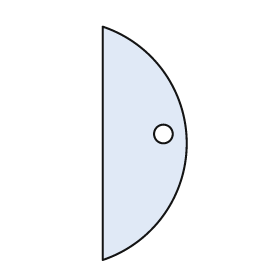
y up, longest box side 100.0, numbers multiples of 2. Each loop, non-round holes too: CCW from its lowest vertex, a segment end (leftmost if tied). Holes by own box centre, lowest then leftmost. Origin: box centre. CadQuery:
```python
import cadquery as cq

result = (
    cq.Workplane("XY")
    .moveTo(-18.0, -50.0)
    .threePointArc((18.0, 0.0), (-18.0, 50.0))
    .close()
    .moveTo(8.0, 4.0)
    .circle(4.0)
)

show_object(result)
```